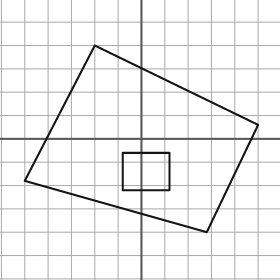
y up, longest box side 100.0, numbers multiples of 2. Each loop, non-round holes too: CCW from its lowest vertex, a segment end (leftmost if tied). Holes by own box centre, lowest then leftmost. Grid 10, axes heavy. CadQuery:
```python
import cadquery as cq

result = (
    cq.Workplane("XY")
    .moveTo(28.0, -40.0)
    .lineTo(50.0, 6.0)
    .lineTo(-20.0, 40.0)
    .lineTo(-50.0, -18.0)
    .close()
    .moveTo(-8.0, -22.0)
    .lineTo(12.0, -22.0)
    .lineTo(12.0, -6.0)
    .lineTo(-8.0, -6.0)
    .close()
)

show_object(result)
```